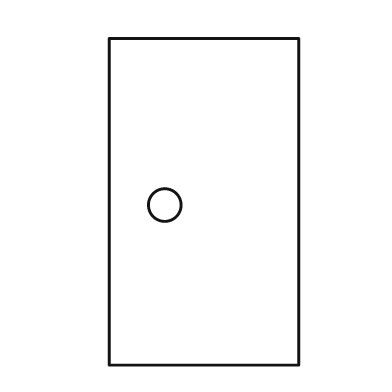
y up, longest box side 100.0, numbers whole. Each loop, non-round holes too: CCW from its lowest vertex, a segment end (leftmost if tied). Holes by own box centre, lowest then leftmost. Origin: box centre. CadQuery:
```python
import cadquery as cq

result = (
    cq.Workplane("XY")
    .moveTo(-29.0, -50.0)
    .lineTo(29.0, -50.0)
    .lineTo(29.0, 50.0)
    .lineTo(-29.0, 50.0)
    .close()
    .moveTo(-12.0, -1.0)
    .circle(5.0)
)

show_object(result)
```